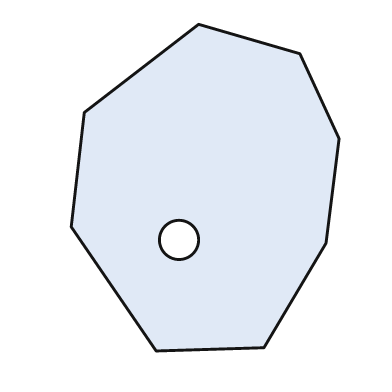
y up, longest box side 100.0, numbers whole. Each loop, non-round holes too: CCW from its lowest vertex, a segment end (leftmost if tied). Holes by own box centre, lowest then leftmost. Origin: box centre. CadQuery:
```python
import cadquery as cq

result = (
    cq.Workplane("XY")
    .moveTo(-15.0, -50.0)
    .lineTo(18.0, -49.0)
    .lineTo(37.0, -17.0)
    .lineTo(41.0, 15.0)
    .lineTo(29.0, 41.0)
    .lineTo(-2.0, 50.0)
    .lineTo(-37.0, 23.0)
    .lineTo(-41.0, -12.0)
    .close()
    .moveTo(-8.0, -16.0)
    .circle(6.0)
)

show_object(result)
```